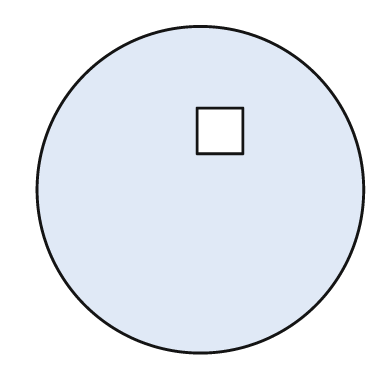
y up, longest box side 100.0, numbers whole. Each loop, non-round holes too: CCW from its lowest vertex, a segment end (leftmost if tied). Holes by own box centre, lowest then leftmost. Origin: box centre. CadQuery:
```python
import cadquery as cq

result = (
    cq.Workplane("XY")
    .moveTo(0.0, 0.0)
    .circle(50.0)
    .moveTo(-1.0, 11.0)
    .lineTo(13.0, 11.0)
    .lineTo(13.0, 25.0)
    .lineTo(-1.0, 25.0)
    .close()
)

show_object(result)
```